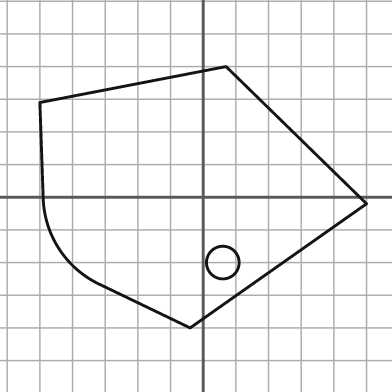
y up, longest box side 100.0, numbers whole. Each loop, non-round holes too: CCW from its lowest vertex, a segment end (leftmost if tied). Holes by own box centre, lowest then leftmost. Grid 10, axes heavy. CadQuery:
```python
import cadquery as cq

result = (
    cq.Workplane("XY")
    .moveTo(-4.0, -40.0)
    .lineTo(50.0, -2.0)
    .lineTo(7.0, 40.0)
    .lineTo(-50.0, 29.0)
    .lineTo(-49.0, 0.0)
    .threePointArc((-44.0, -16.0), (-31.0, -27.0))
    .close()
    .moveTo(6.0, -20.0)
    .circle(5.0)
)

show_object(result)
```